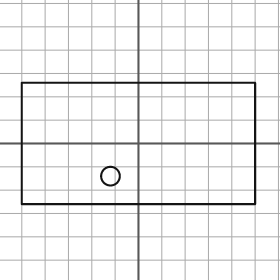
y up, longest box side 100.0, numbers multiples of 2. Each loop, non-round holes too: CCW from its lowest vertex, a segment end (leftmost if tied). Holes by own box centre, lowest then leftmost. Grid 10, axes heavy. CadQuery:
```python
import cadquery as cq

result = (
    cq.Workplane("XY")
    .moveTo(-50.0, -26.0)
    .lineTo(50.0, -26.0)
    .lineTo(50.0, 26.0)
    .lineTo(-50.0, 26.0)
    .close()
    .moveTo(-12.0, -14.0)
    .circle(4.0)
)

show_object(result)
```